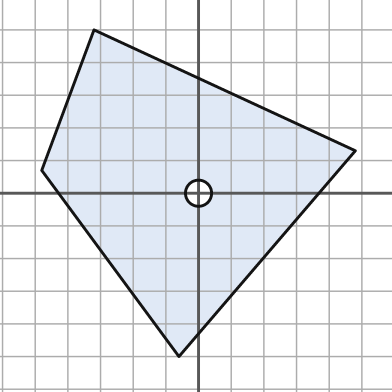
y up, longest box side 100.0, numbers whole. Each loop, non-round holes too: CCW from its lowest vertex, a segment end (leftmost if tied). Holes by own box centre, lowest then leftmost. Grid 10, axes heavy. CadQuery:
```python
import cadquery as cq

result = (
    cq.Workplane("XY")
    .moveTo(-6.0, -50.0)
    .lineTo(48.0, 13.0)
    .lineTo(-32.0, 50.0)
    .lineTo(-48.0, 7.0)
    .close()
    .moveTo(0.0, 0.0)
    .circle(4.0)
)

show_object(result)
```